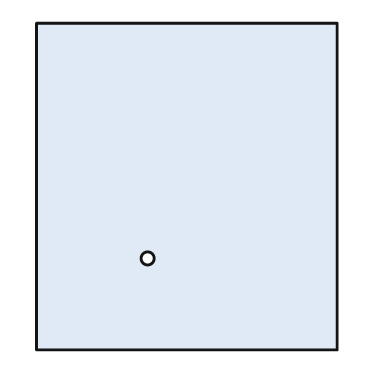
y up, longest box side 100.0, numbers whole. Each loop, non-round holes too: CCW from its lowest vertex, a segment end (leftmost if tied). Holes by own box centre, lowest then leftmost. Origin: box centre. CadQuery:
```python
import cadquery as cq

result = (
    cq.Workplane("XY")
    .moveTo(-46.0, -50.0)
    .lineTo(46.0, -50.0)
    .lineTo(46.0, 50.0)
    .lineTo(-46.0, 50.0)
    .close()
    .moveTo(-12.0, -22.0)
    .circle(2.0)
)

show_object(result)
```